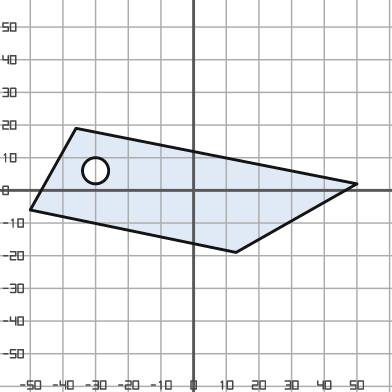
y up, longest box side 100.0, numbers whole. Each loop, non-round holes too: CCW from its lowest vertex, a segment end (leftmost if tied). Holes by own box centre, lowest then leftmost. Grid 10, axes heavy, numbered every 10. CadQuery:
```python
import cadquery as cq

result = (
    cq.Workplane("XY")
    .moveTo(13.0, -19.0)
    .lineTo(50.0, 2.0)
    .lineTo(-36.0, 19.0)
    .lineTo(-50.0, -6.0)
    .close()
    .moveTo(-30.0, 6.0)
    .circle(4.0)
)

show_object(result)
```